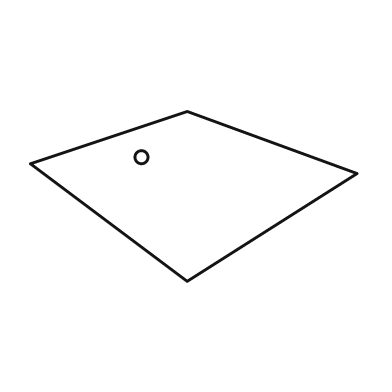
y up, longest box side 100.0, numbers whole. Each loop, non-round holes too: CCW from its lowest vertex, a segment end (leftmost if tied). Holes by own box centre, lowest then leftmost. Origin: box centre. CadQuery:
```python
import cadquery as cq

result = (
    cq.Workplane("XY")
    .moveTo(-2.0, -26.0)
    .lineTo(50.0, 7.0)
    .lineTo(-2.0, 26.0)
    .lineTo(-50.0, 10.0)
    .close()
    .moveTo(-16.0, 12.0)
    .circle(2.0)
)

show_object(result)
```